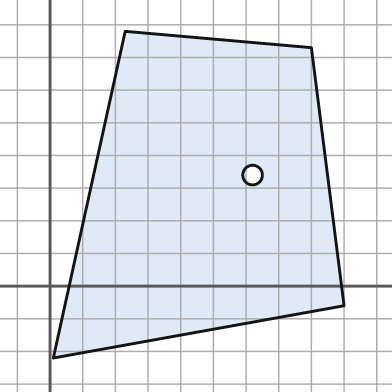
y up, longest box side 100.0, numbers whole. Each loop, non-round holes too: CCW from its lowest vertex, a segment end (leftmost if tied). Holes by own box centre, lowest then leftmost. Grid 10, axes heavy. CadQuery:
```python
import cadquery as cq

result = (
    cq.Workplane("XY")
    .moveTo(1.0, -22.0)
    .lineTo(90.0, -6.0)
    .lineTo(80.0, 73.0)
    .lineTo(23.0, 78.0)
    .close()
    .moveTo(62.0, 34.0)
    .circle(3.0)
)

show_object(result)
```